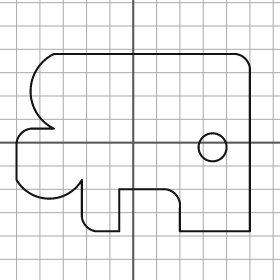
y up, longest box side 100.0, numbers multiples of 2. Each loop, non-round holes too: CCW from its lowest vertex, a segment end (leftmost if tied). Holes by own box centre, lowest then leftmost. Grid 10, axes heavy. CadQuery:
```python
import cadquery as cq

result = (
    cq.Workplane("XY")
    .moveTo(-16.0, -38.0)
    .lineTo(-6.0, -38.0)
    .lineTo(-6.0, -20.0)
    .lineTo(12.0, -20.0)
    .threePointArc((18.0, -22.0), (20.0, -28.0))
    .lineTo(20.0, -38.0)
    .lineTo(50.0, -38.0)
    .lineTo(50.0, 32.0)
    .threePointArc((48.0, 36.0), (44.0, 38.0))
    .lineTo(-34.0, 38.0)
    .threePointArc((-44.0, 22.0), (-34.0, 6.0))
    .lineTo(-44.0, 6.0)
    .threePointArc((-48.0, 4.0), (-50.0, 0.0))
    .lineTo(-50.0, -16.0)
    .threePointArc((-36.0, -24.0), (-22.0, -16.0))
    .lineTo(-22.0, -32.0)
    .threePointArc((-20.0, -36.0), (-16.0, -38.0))
    .close()
    .moveTo(34.0, -2.0)
    .circle(6.0)
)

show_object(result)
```